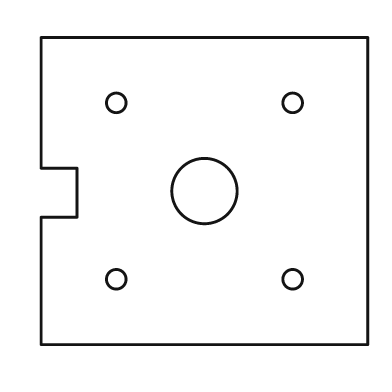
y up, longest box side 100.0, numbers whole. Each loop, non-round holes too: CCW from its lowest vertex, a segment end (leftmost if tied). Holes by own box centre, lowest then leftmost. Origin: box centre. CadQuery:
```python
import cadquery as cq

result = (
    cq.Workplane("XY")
    .moveTo(-50.0, -47.0)
    .lineTo(50.0, -47.0)
    .lineTo(50.0, 47.0)
    .lineTo(-50.0, 47.0)
    .lineTo(-50.0, 7.0)
    .lineTo(-39.0, 7.0)
    .lineTo(-39.0, -8.0)
    .lineTo(-50.0, -8.0)
    .close()
    .moveTo(-27.0, -27.0)
    .circle(3.0)
    .moveTo(27.0, -27.0)
    .circle(3.0)
    .moveTo(0.0, 0.0)
    .circle(10.0)
    .moveTo(-27.0, 27.0)
    .circle(3.0)
    .moveTo(27.0, 27.0)
    .circle(3.0)
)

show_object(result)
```